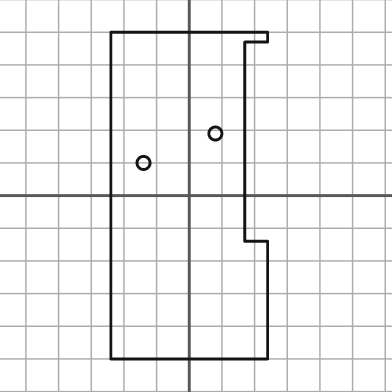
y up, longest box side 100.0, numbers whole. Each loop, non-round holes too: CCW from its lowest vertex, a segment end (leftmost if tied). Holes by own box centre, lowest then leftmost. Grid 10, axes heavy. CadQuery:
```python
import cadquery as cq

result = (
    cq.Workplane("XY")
    .moveTo(-24.0, -50.0)
    .lineTo(24.0, -50.0)
    .lineTo(24.0, -14.0)
    .lineTo(17.0, -14.0)
    .lineTo(17.0, 47.0)
    .lineTo(24.0, 47.0)
    .lineTo(24.0, 50.0)
    .lineTo(-24.0, 50.0)
    .close()
    .moveTo(-14.0, 10.0)
    .circle(2.0)
    .moveTo(8.0, 19.0)
    .circle(2.0)
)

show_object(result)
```